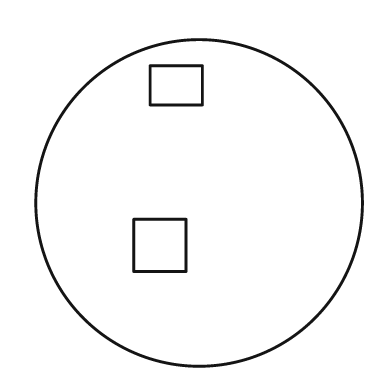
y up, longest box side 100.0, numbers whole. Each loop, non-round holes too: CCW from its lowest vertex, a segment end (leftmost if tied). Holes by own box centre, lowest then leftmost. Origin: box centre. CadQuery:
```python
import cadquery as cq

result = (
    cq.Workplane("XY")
    .moveTo(0.0, 0.0)
    .circle(50.0)
    .moveTo(-20.0, -21.0)
    .lineTo(-4.0, -21.0)
    .lineTo(-4.0, -5.0)
    .lineTo(-20.0, -5.0)
    .close()
    .moveTo(-15.0, 30.0)
    .lineTo(1.0, 30.0)
    .lineTo(1.0, 42.0)
    .lineTo(-15.0, 42.0)
    .close()
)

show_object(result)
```